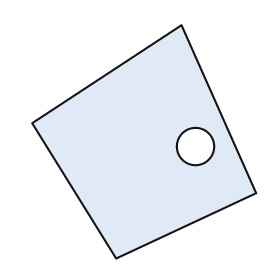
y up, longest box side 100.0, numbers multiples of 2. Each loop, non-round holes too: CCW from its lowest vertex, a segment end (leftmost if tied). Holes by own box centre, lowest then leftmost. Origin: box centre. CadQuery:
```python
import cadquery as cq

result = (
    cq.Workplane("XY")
    .moveTo(-12.0, -50.0)
    .lineTo(48.0, -22.0)
    .lineTo(16.0, 50.0)
    .lineTo(-48.0, 8.0)
    .close()
    .moveTo(22.0, -2.0)
    .circle(8.0)
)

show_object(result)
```